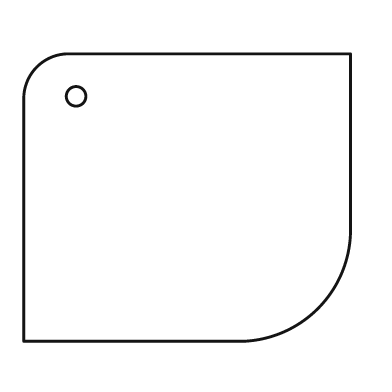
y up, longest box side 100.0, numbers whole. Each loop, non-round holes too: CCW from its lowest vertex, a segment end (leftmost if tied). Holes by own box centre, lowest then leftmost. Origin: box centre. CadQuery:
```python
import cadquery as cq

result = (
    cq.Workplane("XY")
    .moveTo(-50.0, -44.0)
    .lineTo(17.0, -44.0)
    .threePointArc((40.0, -34.0), (50.0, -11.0))
    .lineTo(50.0, 44.0)
    .lineTo(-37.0, 44.0)
    .threePointArc((-46.0, 40.0), (-50.0, 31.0))
    .close()
    .moveTo(-34.0, 31.0)
    .circle(3.0)
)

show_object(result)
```